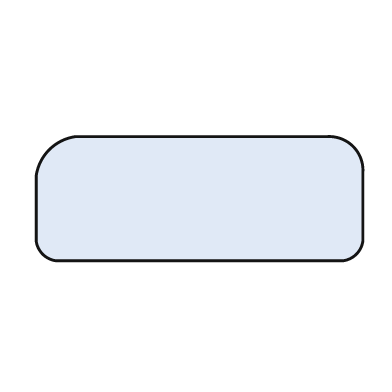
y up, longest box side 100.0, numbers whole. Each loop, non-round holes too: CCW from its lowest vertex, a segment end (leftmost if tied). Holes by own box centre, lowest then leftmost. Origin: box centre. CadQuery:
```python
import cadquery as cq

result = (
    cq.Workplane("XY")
    .moveTo(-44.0, -19.0)
    .lineTo(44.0, -19.0)
    .threePointArc((48.0, -17.0), (50.0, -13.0))
    .lineTo(50.0, 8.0)
    .threePointArc((47.0, 16.0), (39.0, 19.0))
    .lineTo(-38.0, 19.0)
    .threePointArc((-46.0, 15.0), (-50.0, 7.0))
    .lineTo(-50.0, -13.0)
    .threePointArc((-48.0, -17.0), (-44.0, -19.0))
    .close()
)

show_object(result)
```